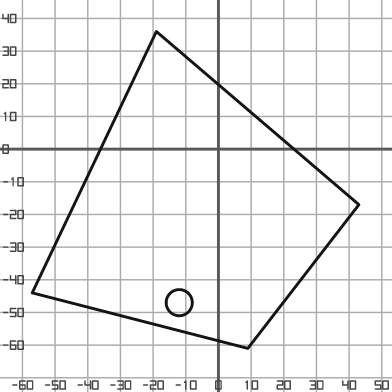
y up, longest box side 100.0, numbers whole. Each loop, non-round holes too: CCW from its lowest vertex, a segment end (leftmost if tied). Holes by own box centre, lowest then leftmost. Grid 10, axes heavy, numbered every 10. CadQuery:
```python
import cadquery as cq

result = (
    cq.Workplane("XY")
    .moveTo(9.0, -61.0)
    .lineTo(43.0, -17.0)
    .lineTo(-19.0, 36.0)
    .lineTo(-57.0, -44.0)
    .close()
    .moveTo(-12.0, -47.0)
    .circle(4.0)
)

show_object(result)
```